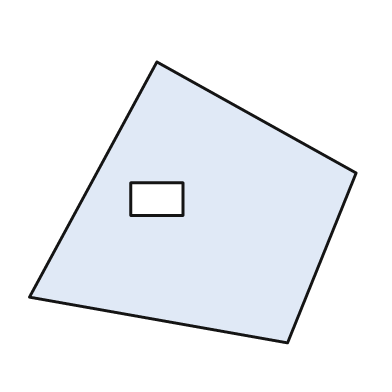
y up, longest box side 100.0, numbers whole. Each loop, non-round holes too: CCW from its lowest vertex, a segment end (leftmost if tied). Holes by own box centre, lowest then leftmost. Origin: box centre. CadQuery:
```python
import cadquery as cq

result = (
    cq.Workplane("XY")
    .moveTo(29.0, -43.0)
    .lineTo(50.0, 9.0)
    .lineTo(-11.0, 43.0)
    .lineTo(-50.0, -29.0)
    .close()
    .moveTo(-19.0, -4.0)
    .lineTo(-3.0, -4.0)
    .lineTo(-3.0, 6.0)
    .lineTo(-19.0, 6.0)
    .close()
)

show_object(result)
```